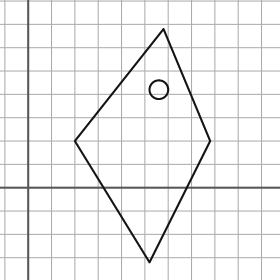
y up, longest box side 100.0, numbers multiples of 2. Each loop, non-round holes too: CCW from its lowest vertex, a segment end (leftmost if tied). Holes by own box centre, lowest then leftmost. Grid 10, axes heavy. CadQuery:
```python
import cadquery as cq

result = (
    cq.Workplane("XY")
    .moveTo(52.0, -32.0)
    .lineTo(78.0, 20.0)
    .lineTo(58.0, 68.0)
    .lineTo(20.0, 20.0)
    .close()
    .moveTo(56.0, 42.0)
    .circle(4.0)
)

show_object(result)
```